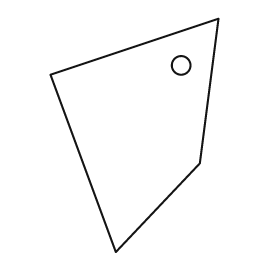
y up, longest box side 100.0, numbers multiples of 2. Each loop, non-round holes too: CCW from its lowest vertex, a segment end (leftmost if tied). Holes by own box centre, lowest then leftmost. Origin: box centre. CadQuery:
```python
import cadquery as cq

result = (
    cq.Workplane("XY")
    .moveTo(-8.0, -50.0)
    .lineTo(28.0, -12.0)
    .lineTo(36.0, 50.0)
    .lineTo(-36.0, 26.0)
    .close()
    .moveTo(20.0, 30.0)
    .circle(4.0)
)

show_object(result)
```